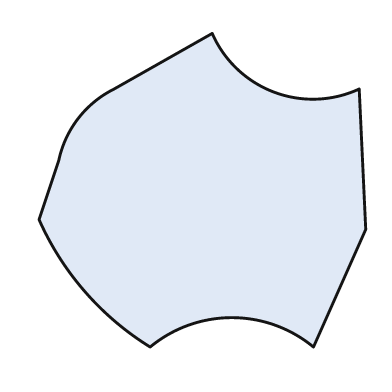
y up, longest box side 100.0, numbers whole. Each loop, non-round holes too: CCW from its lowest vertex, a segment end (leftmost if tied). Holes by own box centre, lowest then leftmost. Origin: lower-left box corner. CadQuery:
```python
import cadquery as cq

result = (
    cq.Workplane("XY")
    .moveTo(34.0, 0.0)
    .threePointArc((59.0, 9.0), (84.0, 0.0))
    .lineTo(100.0, 36.0)
    .lineTo(98.0, 79.0)
    .threePointArc((72.0, 78.0), (53.0, 96.0))
    .lineTo(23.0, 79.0)
    .threePointArc((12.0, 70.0), (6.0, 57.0))
    .lineTo(0.0, 39.0)
    .threePointArc((14.0, 17.0), (34.0, 0.0))
    .close()
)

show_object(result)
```